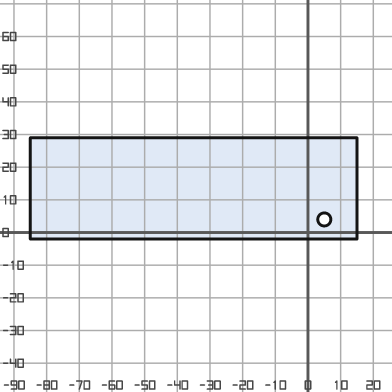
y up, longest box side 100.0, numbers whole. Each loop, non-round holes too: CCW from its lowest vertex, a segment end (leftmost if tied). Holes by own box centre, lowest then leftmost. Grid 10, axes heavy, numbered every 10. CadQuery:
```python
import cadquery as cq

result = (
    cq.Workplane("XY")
    .moveTo(-85.0, -2.0)
    .lineTo(15.0, -2.0)
    .lineTo(15.0, 29.0)
    .lineTo(-85.0, 29.0)
    .close()
    .moveTo(5.0, 4.0)
    .circle(2.0)
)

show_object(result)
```